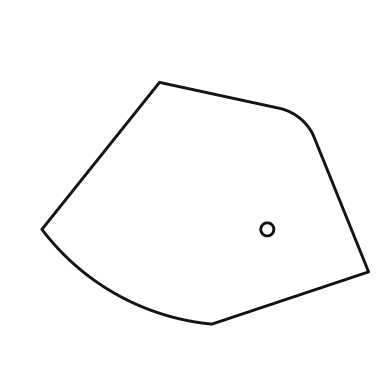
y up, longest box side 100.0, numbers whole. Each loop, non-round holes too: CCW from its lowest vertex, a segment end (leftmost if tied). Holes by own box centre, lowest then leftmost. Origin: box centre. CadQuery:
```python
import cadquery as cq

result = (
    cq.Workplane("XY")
    .moveTo(2.0, -37.0)
    .lineTo(50.0, -21.0)
    .lineTo(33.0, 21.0)
    .threePointArc((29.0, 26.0), (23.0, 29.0))
    .lineTo(-14.0, 37.0)
    .lineTo(-50.0, -8.0)
    .threePointArc((-27.0, -28.0), (2.0, -37.0))
    .close()
    .moveTo(19.0, -8.0)
    .circle(2.0)
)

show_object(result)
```